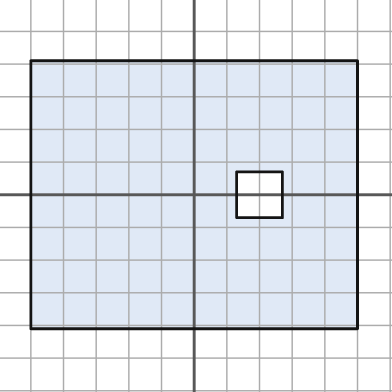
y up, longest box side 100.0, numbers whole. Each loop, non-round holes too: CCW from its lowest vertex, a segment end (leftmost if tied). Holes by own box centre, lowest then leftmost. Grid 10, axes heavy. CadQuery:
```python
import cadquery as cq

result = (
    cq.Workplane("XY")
    .moveTo(-50.0, -41.0)
    .lineTo(50.0, -41.0)
    .lineTo(50.0, 41.0)
    .lineTo(-50.0, 41.0)
    .close()
    .moveTo(13.0, -7.0)
    .lineTo(27.0, -7.0)
    .lineTo(27.0, 7.0)
    .lineTo(13.0, 7.0)
    .close()
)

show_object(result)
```